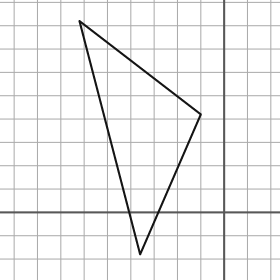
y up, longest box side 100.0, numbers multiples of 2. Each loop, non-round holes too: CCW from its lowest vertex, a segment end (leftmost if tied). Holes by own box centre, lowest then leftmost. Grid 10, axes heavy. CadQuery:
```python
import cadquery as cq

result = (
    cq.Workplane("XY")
    .moveTo(-36.0, -18.0)
    .lineTo(-10.0, 42.0)
    .lineTo(-62.0, 82.0)
    .close()
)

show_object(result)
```